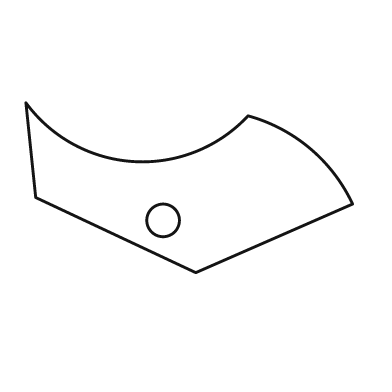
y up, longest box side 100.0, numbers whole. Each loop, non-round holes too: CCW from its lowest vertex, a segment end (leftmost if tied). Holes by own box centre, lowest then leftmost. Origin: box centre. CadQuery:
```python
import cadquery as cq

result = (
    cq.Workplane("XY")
    .moveTo(2.0, -26.0)
    .lineTo(50.0, -5.0)
    .threePointArc((37.0, 12.0), (18.0, 22.0))
    .threePointArc((-17.0, 8.0), (-50.0, 26.0))
    .lineTo(-47.0, -3.0)
    .close()
    .moveTo(-8.0, -10.0)
    .circle(5.0)
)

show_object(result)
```